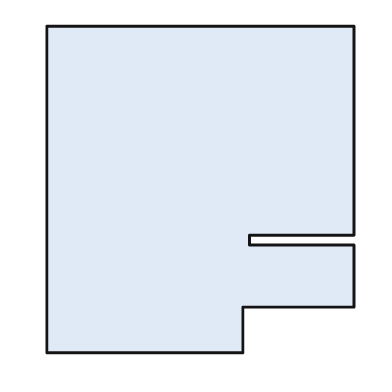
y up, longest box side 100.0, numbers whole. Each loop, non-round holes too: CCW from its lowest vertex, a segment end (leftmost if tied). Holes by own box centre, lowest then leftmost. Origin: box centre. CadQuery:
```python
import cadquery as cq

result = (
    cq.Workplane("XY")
    .moveTo(-47.0, -50.0)
    .lineTo(13.0, -50.0)
    .lineTo(13.0, -36.0)
    .lineTo(47.0, -36.0)
    .lineTo(47.0, -17.0)
    .lineTo(15.0, -17.0)
    .lineTo(15.0, -14.0)
    .lineTo(47.0, -14.0)
    .lineTo(47.0, 50.0)
    .lineTo(-47.0, 50.0)
    .close()
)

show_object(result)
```